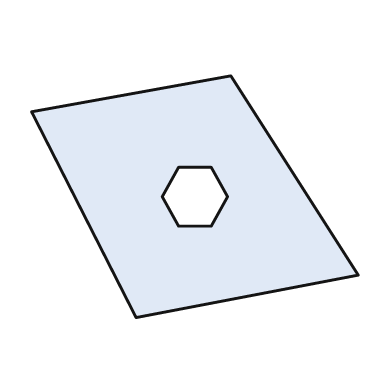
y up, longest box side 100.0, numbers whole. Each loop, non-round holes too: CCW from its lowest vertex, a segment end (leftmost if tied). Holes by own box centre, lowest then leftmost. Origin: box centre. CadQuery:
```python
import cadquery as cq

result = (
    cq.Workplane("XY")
    .moveTo(-18.0, -37.0)
    .lineTo(50.0, -24.0)
    .lineTo(11.0, 37.0)
    .lineTo(-50.0, 26.0)
    .close()
    .moveTo(-5.0, -9.0)
    .lineTo(5.0, -9.0)
    .lineTo(10.0, 0.0)
    .lineTo(5.0, 9.0)
    .lineTo(-5.0, 9.0)
    .lineTo(-10.0, 0.0)
    .close()
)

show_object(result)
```